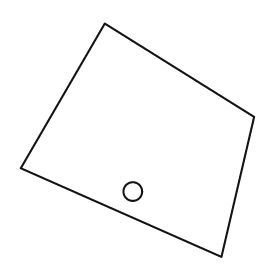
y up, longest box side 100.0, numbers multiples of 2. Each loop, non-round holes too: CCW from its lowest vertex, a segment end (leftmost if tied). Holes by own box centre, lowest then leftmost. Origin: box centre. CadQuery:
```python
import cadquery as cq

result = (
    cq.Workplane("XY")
    .moveTo(36.0, -50.0)
    .lineTo(50.0, 10.0)
    .lineTo(-14.0, 50.0)
    .lineTo(-50.0, -12.0)
    .close()
    .moveTo(-2.0, -22.0)
    .circle(4.0)
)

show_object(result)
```